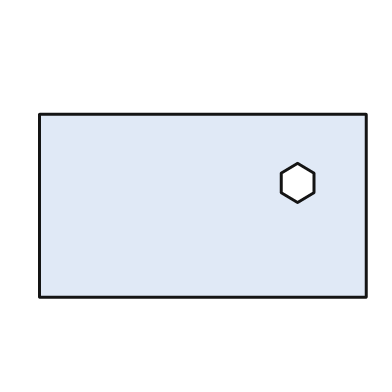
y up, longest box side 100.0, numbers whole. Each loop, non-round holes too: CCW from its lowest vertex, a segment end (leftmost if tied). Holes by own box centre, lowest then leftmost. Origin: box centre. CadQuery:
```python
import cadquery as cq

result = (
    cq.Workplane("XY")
    .moveTo(-50.0, -28.0)
    .lineTo(50.0, -28.0)
    .lineTo(50.0, 28.0)
    .lineTo(-50.0, 28.0)
    .close()
    .moveTo(29.0, 1.0)
    .lineTo(34.0, 4.0)
    .lineTo(34.0, 10.0)
    .lineTo(29.0, 13.0)
    .lineTo(24.0, 10.0)
    .lineTo(24.0, 4.0)
    .close()
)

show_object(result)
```